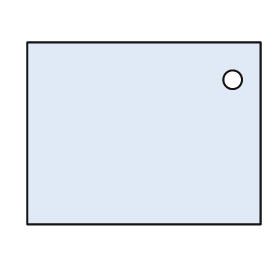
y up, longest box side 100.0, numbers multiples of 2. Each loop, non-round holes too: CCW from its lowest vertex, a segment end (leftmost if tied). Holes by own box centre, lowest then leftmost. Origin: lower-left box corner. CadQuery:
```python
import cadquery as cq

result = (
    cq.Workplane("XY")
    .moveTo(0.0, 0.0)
    .lineTo(100.0, 0.0)
    .lineTo(100.0, 78.0)
    .lineTo(0.0, 78.0)
    .close()
    .moveTo(88.0, 62.0)
    .circle(4.0)
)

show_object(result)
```